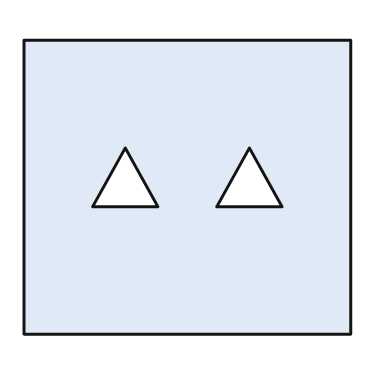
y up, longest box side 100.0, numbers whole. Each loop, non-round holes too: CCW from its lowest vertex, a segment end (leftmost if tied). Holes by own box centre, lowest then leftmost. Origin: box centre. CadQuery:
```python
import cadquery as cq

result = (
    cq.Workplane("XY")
    .moveTo(-50.0, -45.0)
    .lineTo(50.0, -45.0)
    .lineTo(50.0, 45.0)
    .lineTo(-50.0, 45.0)
    .close()
    .moveTo(-29.0, -6.0)
    .lineTo(-9.0, -6.0)
    .lineTo(-19.0, 12.0)
    .close()
    .moveTo(9.0, -6.0)
    .lineTo(29.0, -6.0)
    .lineTo(19.0, 12.0)
    .close()
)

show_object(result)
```